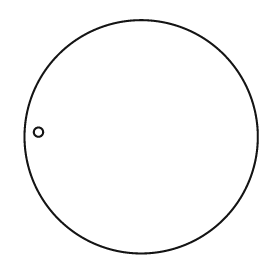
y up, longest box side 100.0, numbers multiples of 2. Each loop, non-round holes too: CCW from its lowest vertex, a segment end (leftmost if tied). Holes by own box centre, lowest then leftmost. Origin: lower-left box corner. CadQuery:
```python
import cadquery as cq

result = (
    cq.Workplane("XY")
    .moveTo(50.0, 50.0)
    .circle(50.0)
    .moveTo(6.0, 52.0)
    .circle(2.0)
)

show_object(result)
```